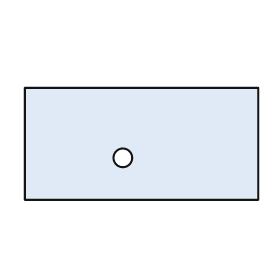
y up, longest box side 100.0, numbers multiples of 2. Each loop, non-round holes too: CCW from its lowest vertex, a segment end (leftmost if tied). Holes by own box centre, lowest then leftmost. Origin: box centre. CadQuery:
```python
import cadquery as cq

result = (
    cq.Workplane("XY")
    .moveTo(-50.0, -24.0)
    .lineTo(50.0, -24.0)
    .lineTo(50.0, 24.0)
    .lineTo(-50.0, 24.0)
    .close()
    .moveTo(-8.0, -6.0)
    .circle(4.0)
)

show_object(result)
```